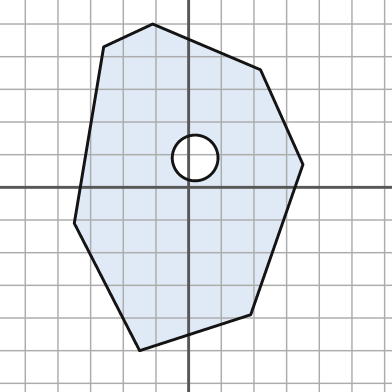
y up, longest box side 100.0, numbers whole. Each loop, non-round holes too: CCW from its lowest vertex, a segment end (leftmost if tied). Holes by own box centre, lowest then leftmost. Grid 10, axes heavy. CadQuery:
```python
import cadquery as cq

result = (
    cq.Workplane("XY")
    .moveTo(-15.0, -50.0)
    .lineTo(19.0, -39.0)
    .lineTo(35.0, 7.0)
    .lineTo(22.0, 36.0)
    .lineTo(-11.0, 50.0)
    .lineTo(-26.0, 43.0)
    .lineTo(-35.0, -11.0)
    .close()
    .moveTo(2.0, 9.0)
    .circle(7.0)
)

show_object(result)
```